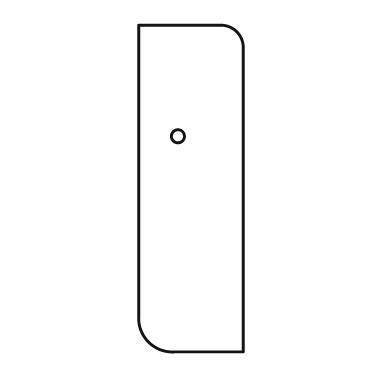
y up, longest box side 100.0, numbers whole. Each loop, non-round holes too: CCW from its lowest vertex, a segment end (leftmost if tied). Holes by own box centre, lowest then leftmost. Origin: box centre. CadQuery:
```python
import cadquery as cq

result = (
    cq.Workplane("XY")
    .moveTo(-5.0, -50.0)
    .lineTo(16.0, -50.0)
    .lineTo(16.0, 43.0)
    .threePointArc((14.0, 48.0), (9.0, 50.0))
    .lineTo(-16.0, 50.0)
    .lineTo(-16.0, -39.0)
    .threePointArc((-13.0, -47.0), (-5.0, -50.0))
    .close()
    .moveTo(-4.0, 16.0)
    .circle(2.0)
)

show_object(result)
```